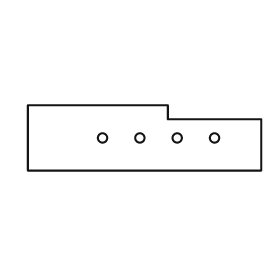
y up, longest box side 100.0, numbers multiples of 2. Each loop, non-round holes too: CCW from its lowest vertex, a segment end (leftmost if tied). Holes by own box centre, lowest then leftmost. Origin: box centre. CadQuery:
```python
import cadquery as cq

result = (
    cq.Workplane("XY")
    .moveTo(-50.0, -14.0)
    .lineTo(50.0, -14.0)
    .lineTo(50.0, 8.0)
    .lineTo(10.0, 8.0)
    .lineTo(10.0, 14.0)
    .lineTo(-50.0, 14.0)
    .close()
    .moveTo(-18.0, 0.0)
    .circle(2.0)
    .moveTo(-2.0, 0.0)
    .circle(2.0)
    .moveTo(14.0, 0.0)
    .circle(2.0)
    .moveTo(30.0, 0.0)
    .circle(2.0)
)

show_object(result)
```